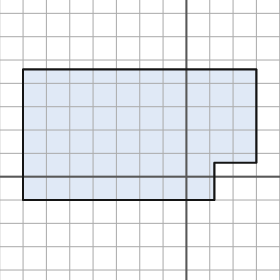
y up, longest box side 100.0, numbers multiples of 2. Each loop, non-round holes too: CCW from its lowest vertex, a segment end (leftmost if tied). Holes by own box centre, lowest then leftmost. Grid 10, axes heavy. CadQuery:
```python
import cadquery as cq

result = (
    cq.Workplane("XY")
    .moveTo(-70.0, -10.0)
    .lineTo(12.0, -10.0)
    .lineTo(12.0, 6.0)
    .lineTo(30.0, 6.0)
    .lineTo(30.0, 46.0)
    .lineTo(-70.0, 46.0)
    .close()
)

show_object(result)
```